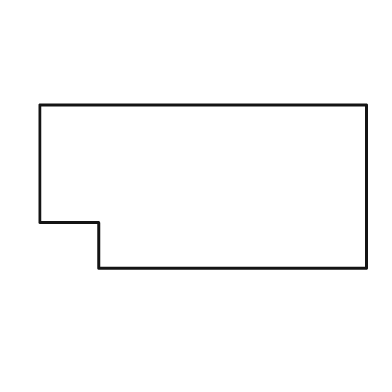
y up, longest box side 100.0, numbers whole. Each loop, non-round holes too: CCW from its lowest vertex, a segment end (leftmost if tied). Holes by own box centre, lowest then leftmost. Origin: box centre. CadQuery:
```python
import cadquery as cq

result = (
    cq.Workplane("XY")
    .moveTo(-32.0, -25.0)
    .lineTo(50.0, -25.0)
    .lineTo(50.0, 25.0)
    .lineTo(-50.0, 25.0)
    .lineTo(-50.0, -11.0)
    .lineTo(-32.0, -11.0)
    .close()
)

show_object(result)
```